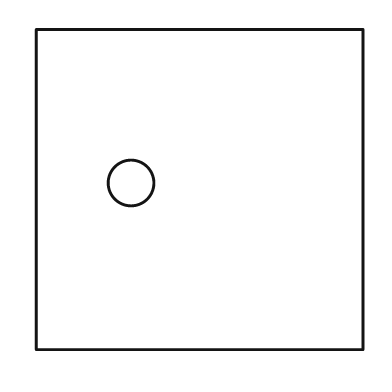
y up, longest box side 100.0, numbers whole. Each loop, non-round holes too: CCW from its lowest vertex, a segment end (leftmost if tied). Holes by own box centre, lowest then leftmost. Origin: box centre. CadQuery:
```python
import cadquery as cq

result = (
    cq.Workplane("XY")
    .moveTo(-50.0, -49.0)
    .lineTo(50.0, -49.0)
    .lineTo(50.0, 49.0)
    .lineTo(-50.0, 49.0)
    .close()
    .moveTo(-21.0, 2.0)
    .circle(7.0)
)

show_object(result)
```